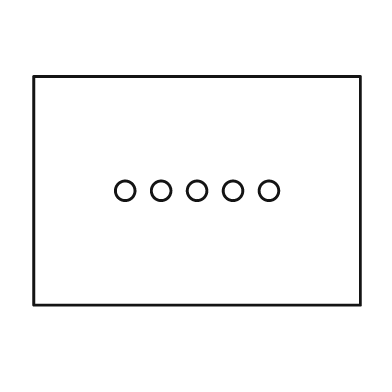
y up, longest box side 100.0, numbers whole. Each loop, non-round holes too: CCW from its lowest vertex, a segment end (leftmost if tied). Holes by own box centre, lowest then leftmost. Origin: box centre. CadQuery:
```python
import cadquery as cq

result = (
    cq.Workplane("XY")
    .moveTo(-50.0, -35.0)
    .lineTo(50.0, -35.0)
    .lineTo(50.0, 35.0)
    .lineTo(-50.0, 35.0)
    .close()
    .moveTo(-22.0, 0.0)
    .circle(3.0)
    .moveTo(-11.0, 0.0)
    .circle(3.0)
    .moveTo(0.0, 0.0)
    .circle(3.0)
    .moveTo(11.0, 0.0)
    .circle(3.0)
    .moveTo(22.0, 0.0)
    .circle(3.0)
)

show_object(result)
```